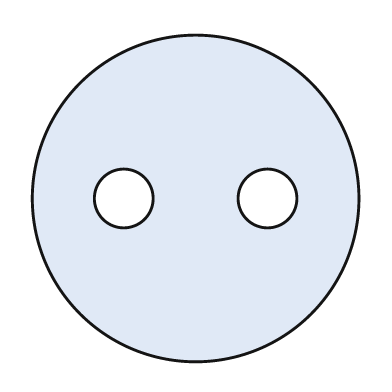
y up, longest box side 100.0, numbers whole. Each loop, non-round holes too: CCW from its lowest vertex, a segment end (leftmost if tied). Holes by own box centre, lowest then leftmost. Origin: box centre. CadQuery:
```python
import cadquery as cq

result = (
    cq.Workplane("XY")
    .moveTo(0.0, 0.0)
    .circle(50.0)
    .moveTo(-22.0, 0.0)
    .circle(9.0)
    .moveTo(22.0, 0.0)
    .circle(9.0)
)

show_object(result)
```